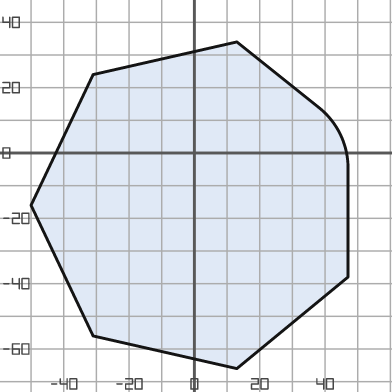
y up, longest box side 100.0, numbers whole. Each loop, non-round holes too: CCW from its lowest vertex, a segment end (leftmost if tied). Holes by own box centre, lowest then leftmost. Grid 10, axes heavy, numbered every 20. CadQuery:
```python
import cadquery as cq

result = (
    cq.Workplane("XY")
    .moveTo(13.0, -66.0)
    .lineTo(47.0, -38.0)
    .lineTo(47.0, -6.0)
    .threePointArc((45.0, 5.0), (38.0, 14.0))
    .lineTo(13.0, 34.0)
    .lineTo(-31.0, 24.0)
    .lineTo(-50.0, -16.0)
    .lineTo(-31.0, -56.0)
    .close()
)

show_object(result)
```